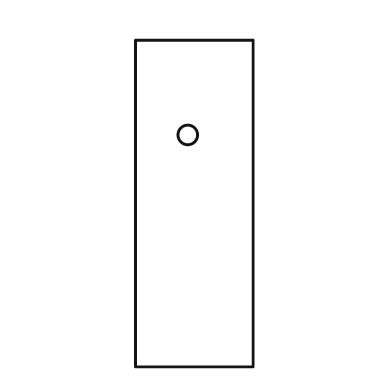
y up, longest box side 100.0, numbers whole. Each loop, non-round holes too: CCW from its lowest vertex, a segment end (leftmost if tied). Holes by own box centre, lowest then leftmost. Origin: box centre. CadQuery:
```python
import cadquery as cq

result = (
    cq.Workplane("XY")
    .moveTo(-18.0, -50.0)
    .lineTo(18.0, -50.0)
    .lineTo(18.0, 50.0)
    .lineTo(-18.0, 50.0)
    .close()
    .moveTo(-2.0, 21.0)
    .circle(3.0)
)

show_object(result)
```